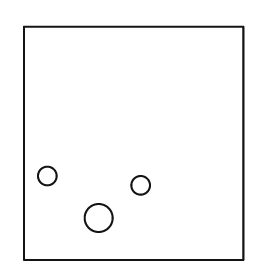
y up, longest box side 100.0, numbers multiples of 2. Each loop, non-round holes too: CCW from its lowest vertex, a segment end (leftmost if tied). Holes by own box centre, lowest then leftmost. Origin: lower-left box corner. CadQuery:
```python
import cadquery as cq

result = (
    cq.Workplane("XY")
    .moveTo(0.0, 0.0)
    .lineTo(94.0, 0.0)
    .lineTo(94.0, 100.0)
    .lineTo(0.0, 100.0)
    .close()
    .moveTo(32.0, 18.0)
    .circle(6.0)
    .moveTo(50.0, 32.0)
    .circle(4.0)
    .moveTo(10.0, 36.0)
    .circle(4.0)
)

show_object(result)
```